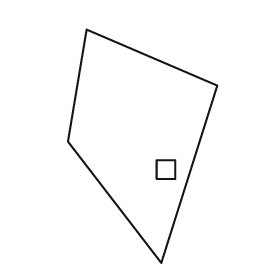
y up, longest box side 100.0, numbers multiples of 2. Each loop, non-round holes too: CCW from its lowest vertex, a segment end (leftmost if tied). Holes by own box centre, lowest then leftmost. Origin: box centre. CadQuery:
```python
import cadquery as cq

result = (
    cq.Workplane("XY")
    .moveTo(8.0, -50.0)
    .lineTo(32.0, 26.0)
    .lineTo(-24.0, 50.0)
    .lineTo(-32.0, 2.0)
    .close()
    .moveTo(6.0, -14.0)
    .lineTo(14.0, -14.0)
    .lineTo(14.0, -6.0)
    .lineTo(6.0, -6.0)
    .close()
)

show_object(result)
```